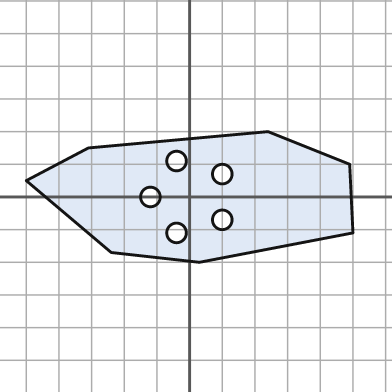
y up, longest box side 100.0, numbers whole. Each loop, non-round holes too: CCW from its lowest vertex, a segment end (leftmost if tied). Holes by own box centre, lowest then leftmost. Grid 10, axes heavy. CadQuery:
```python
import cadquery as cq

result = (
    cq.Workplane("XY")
    .moveTo(3.0, -20.0)
    .lineTo(50.0, -11.0)
    .lineTo(49.0, 10.0)
    .lineTo(24.0, 20.0)
    .lineTo(-31.0, 15.0)
    .lineTo(-50.0, 5.0)
    .lineTo(-24.0, -17.0)
    .close()
    .moveTo(-4.0, -11.0)
    .circle(3.0)
    .moveTo(10.0, -7.0)
    .circle(3.0)
    .moveTo(-12.0, 0.0)
    .circle(3.0)
    .moveTo(10.0, 7.0)
    .circle(3.0)
    .moveTo(-4.0, 11.0)
    .circle(3.0)
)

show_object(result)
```